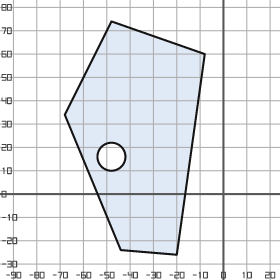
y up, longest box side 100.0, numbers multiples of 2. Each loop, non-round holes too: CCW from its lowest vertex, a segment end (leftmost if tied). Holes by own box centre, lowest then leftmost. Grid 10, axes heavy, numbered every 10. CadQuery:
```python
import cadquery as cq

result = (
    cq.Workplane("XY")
    .moveTo(-20.0, -26.0)
    .lineTo(-8.0, 60.0)
    .lineTo(-48.0, 74.0)
    .lineTo(-68.0, 34.0)
    .lineTo(-44.0, -24.0)
    .close()
    .moveTo(-48.0, 16.0)
    .circle(6.0)
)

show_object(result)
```